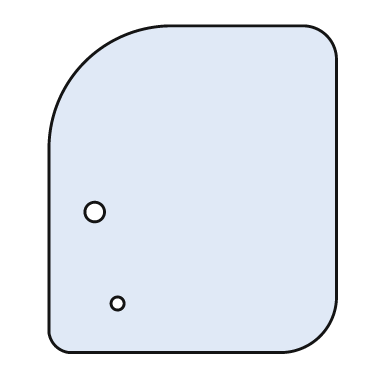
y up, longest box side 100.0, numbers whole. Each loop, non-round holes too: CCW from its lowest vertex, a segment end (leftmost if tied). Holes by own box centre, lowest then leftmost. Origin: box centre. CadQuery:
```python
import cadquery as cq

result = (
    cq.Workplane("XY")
    .moveTo(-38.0, -50.0)
    .lineTo(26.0, -50.0)
    .threePointArc((39.0, -45.0), (44.0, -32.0))
    .lineTo(44.0, 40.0)
    .threePointArc((41.0, 47.0), (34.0, 50.0))
    .lineTo(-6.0, 50.0)
    .threePointArc((-33.0, 39.0), (-44.0, 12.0))
    .lineTo(-44.0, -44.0)
    .threePointArc((-42.0, -48.0), (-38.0, -50.0))
    .close()
    .moveTo(-23.0, -35.0)
    .circle(2.0)
    .moveTo(-30.0, -7.0)
    .circle(3.0)
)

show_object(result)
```